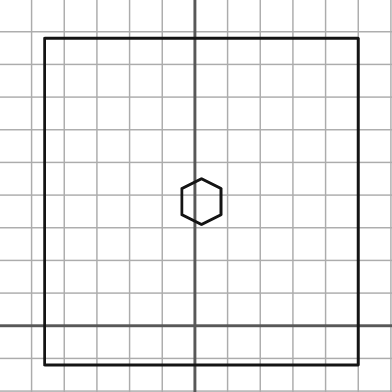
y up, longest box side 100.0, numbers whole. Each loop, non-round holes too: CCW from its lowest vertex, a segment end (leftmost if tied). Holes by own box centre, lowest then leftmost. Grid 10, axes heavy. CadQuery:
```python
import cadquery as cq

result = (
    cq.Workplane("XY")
    .moveTo(-46.0, -12.0)
    .lineTo(50.0, -12.0)
    .lineTo(50.0, 88.0)
    .lineTo(-46.0, 88.0)
    .close()
    .moveTo(2.0, 31.0)
    .lineTo(8.0, 34.0)
    .lineTo(8.0, 42.0)
    .lineTo(2.0, 45.0)
    .lineTo(-4.0, 42.0)
    .lineTo(-4.0, 34.0)
    .close()
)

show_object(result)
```